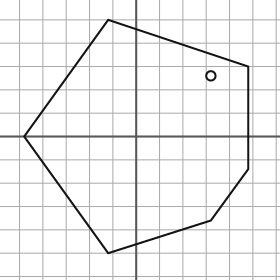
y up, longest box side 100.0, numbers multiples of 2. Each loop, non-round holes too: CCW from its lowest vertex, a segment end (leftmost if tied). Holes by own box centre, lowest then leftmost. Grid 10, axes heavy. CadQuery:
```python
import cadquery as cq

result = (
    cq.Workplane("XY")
    .moveTo(-12.0, -50.0)
    .lineTo(32.0, -36.0)
    .lineTo(48.0, -14.0)
    .lineTo(48.0, 30.0)
    .lineTo(-12.0, 50.0)
    .lineTo(-48.0, 0.0)
    .close()
    .moveTo(32.0, 26.0)
    .circle(2.0)
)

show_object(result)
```